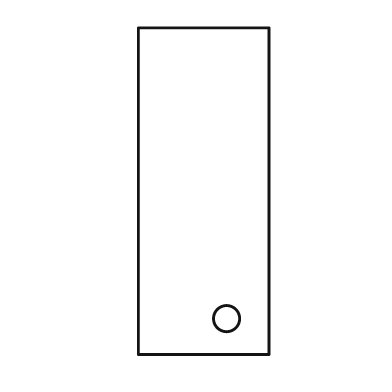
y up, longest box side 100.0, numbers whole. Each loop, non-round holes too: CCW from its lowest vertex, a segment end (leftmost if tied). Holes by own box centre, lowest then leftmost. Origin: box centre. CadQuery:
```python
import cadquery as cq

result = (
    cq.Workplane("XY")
    .moveTo(-20.0, -50.0)
    .lineTo(20.0, -50.0)
    .lineTo(20.0, 50.0)
    .lineTo(-20.0, 50.0)
    .close()
    .moveTo(7.0, -39.0)
    .circle(4.0)
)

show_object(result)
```